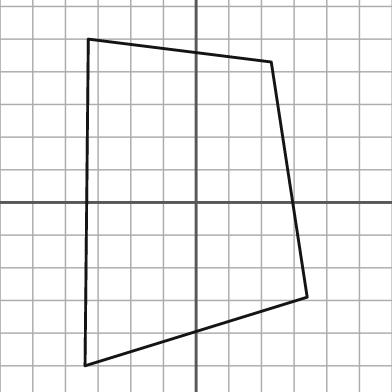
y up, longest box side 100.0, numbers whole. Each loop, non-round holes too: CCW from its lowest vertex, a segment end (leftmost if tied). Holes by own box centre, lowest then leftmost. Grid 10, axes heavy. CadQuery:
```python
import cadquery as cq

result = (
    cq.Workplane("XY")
    .moveTo(-34.0, -50.0)
    .lineTo(34.0, -29.0)
    .lineTo(23.0, 43.0)
    .lineTo(-33.0, 50.0)
    .close()
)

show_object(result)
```